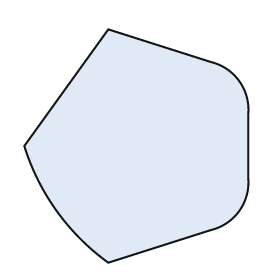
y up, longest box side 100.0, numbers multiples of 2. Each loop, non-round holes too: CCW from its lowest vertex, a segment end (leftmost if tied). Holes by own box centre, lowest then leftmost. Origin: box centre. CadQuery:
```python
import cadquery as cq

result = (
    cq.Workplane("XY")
    .moveTo(-12.0, -50.0)
    .lineTo(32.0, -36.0)
    .threePointArc((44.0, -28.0), (48.0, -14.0))
    .lineTo(48.0, 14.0)
    .threePointArc((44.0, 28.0), (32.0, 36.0))
    .lineTo(-12.0, 50.0)
    .lineTo(-48.0, 0.0)
    .threePointArc((-34.0, -28.0), (-12.0, -50.0))
    .close()
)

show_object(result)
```